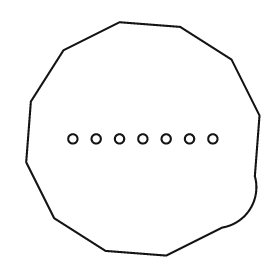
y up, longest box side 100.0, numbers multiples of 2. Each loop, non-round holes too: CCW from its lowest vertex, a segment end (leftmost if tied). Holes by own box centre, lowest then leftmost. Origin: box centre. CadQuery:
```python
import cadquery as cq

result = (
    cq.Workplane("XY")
    .moveTo(10.0, -50.0)
    .lineTo(34.0, -38.0)
    .threePointArc((46.0, -30.0), (48.0, -16.0))
    .lineTo(50.0, 10.0)
    .lineTo(38.0, 34.0)
    .lineTo(16.0, 48.0)
    .lineTo(-10.0, 50.0)
    .lineTo(-34.0, 38.0)
    .lineTo(-48.0, 16.0)
    .lineTo(-50.0, -10.0)
    .lineTo(-38.0, -34.0)
    .lineTo(-16.0, -48.0)
    .close()
    .moveTo(-30.0, 0.0)
    .circle(2.0)
    .moveTo(-20.0, 0.0)
    .circle(2.0)
    .moveTo(-10.0, 0.0)
    .circle(2.0)
    .moveTo(0.0, 0.0)
    .circle(2.0)
    .moveTo(10.0, 0.0)
    .circle(2.0)
    .moveTo(20.0, 0.0)
    .circle(2.0)
    .moveTo(30.0, 0.0)
    .circle(2.0)
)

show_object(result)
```